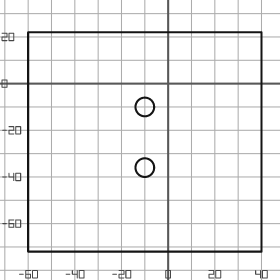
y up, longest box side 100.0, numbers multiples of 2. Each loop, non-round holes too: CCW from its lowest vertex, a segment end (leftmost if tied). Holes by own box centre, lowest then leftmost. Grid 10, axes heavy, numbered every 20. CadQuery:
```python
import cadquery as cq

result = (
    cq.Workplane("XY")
    .moveTo(-60.0, -72.0)
    .lineTo(40.0, -72.0)
    .lineTo(40.0, 22.0)
    .lineTo(-60.0, 22.0)
    .close()
    .moveTo(-10.0, -36.0)
    .circle(4.0)
    .moveTo(-10.0, -10.0)
    .circle(4.0)
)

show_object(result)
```